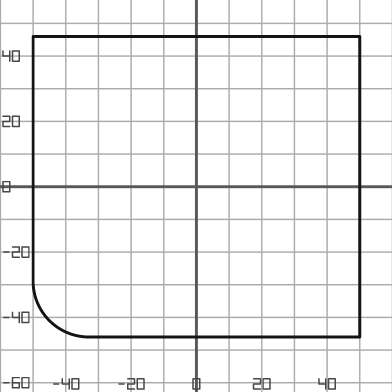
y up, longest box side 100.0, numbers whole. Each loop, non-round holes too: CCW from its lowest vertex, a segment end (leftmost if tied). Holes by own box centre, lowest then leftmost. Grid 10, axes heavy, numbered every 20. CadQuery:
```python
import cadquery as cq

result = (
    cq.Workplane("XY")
    .moveTo(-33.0, -46.0)
    .lineTo(50.0, -46.0)
    .lineTo(50.0, 46.0)
    .lineTo(-50.0, 46.0)
    .lineTo(-50.0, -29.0)
    .threePointArc((-45.0, -41.0), (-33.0, -46.0))
    .close()
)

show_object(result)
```